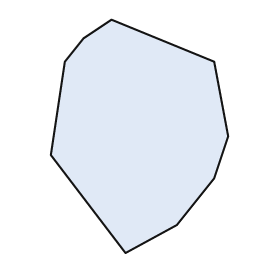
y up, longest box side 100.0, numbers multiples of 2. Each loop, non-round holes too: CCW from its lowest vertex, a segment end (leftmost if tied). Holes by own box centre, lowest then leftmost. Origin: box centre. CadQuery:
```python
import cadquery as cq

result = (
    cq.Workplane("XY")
    .moveTo(-6.0, -50.0)
    .lineTo(16.0, -38.0)
    .lineTo(32.0, -18.0)
    .lineTo(38.0, 0.0)
    .lineTo(32.0, 32.0)
    .lineTo(-12.0, 50.0)
    .lineTo(-24.0, 42.0)
    .lineTo(-32.0, 32.0)
    .lineTo(-38.0, -8.0)
    .close()
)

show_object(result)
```